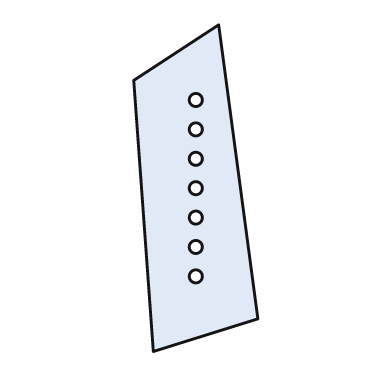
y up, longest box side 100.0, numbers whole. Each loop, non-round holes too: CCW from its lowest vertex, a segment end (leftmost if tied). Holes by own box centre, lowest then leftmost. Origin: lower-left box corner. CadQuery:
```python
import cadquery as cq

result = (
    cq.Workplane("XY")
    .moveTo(6.0, 0.0)
    .lineTo(38.0, 10.0)
    .lineTo(26.0, 100.0)
    .lineTo(0.0, 83.0)
    .close()
    .moveTo(19.0, 23.0)
    .circle(2.0)
    .moveTo(19.0, 32.0)
    .circle(2.0)
    .moveTo(19.0, 41.0)
    .circle(2.0)
    .moveTo(19.0, 50.0)
    .circle(2.0)
    .moveTo(19.0, 59.0)
    .circle(2.0)
    .moveTo(19.0, 68.0)
    .circle(2.0)
    .moveTo(19.0, 77.0)
    .circle(2.0)
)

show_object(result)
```